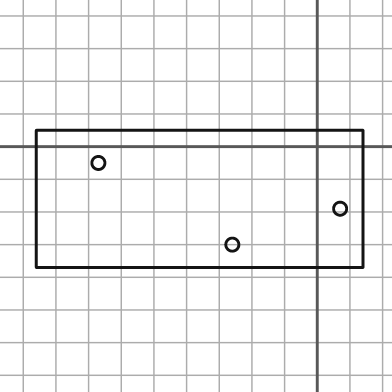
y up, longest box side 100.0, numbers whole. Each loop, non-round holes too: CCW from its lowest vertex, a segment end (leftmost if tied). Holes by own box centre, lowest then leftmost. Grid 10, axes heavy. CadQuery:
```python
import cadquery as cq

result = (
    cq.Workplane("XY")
    .moveTo(-86.0, -37.0)
    .lineTo(14.0, -37.0)
    .lineTo(14.0, 5.0)
    .lineTo(-86.0, 5.0)
    .close()
    .moveTo(-26.0, -30.0)
    .circle(2.0)
    .moveTo(7.0, -19.0)
    .circle(2.0)
    .moveTo(-67.0, -5.0)
    .circle(2.0)
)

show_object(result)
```